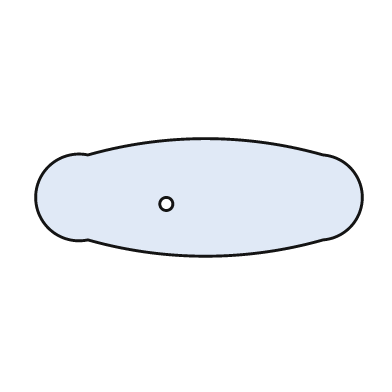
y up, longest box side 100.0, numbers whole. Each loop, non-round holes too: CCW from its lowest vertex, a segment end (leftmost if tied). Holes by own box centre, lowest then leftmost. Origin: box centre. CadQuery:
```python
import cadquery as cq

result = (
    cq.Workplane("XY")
    .moveTo(-34.0, -13.0)
    .threePointArc((2.0, -18.0), (38.0, -13.0))
    .threePointArc((50.0, 0.0), (38.0, 13.0))
    .threePointArc((2.0, 18.0), (-34.0, 13.0))
    .threePointArc((-50.0, 0.0), (-34.0, -13.0))
    .close()
    .moveTo(-10.0, -2.0)
    .circle(2.0)
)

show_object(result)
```